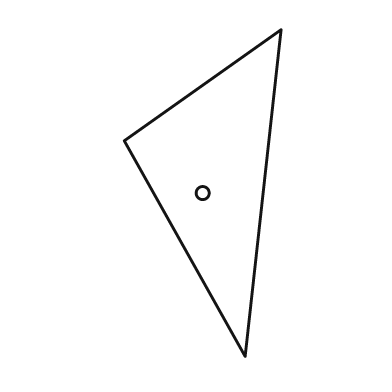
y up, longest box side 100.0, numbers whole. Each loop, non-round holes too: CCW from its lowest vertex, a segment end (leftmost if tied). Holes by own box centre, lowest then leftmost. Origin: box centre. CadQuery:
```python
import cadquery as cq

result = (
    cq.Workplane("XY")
    .moveTo(13.0, -50.0)
    .lineTo(24.0, 50.0)
    .lineTo(-24.0, 16.0)
    .close()
    .moveTo(0.0, 0.0)
    .circle(2.0)
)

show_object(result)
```